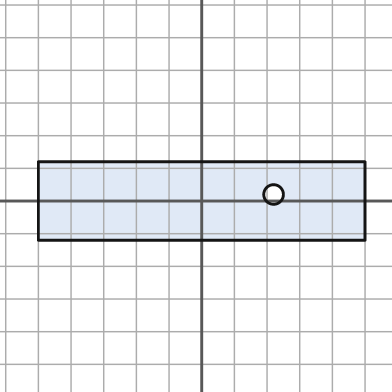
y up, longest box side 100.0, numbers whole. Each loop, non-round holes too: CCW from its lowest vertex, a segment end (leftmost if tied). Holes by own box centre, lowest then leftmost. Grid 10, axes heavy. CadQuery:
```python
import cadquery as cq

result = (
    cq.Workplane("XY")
    .moveTo(-50.0, -12.0)
    .lineTo(50.0, -12.0)
    .lineTo(50.0, 12.0)
    .lineTo(-50.0, 12.0)
    .close()
    .moveTo(22.0, 2.0)
    .circle(3.0)
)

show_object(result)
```